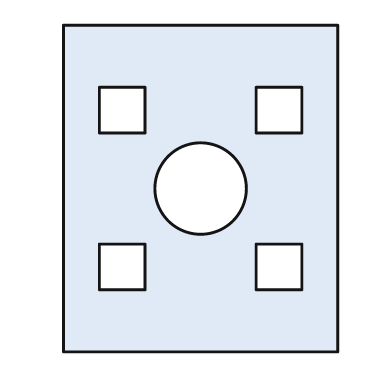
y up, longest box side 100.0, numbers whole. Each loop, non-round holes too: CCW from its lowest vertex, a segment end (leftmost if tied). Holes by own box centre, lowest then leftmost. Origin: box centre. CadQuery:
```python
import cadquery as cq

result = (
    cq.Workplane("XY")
    .moveTo(-42.0, -50.0)
    .lineTo(42.0, -50.0)
    .lineTo(42.0, 50.0)
    .lineTo(-42.0, 50.0)
    .close()
    .moveTo(-31.0, -31.0)
    .lineTo(-17.0, -31.0)
    .lineTo(-17.0, -17.0)
    .lineTo(-31.0, -17.0)
    .close()
    .moveTo(17.0, -31.0)
    .lineTo(31.0, -31.0)
    .lineTo(31.0, -17.0)
    .lineTo(17.0, -17.0)
    .close()
    .moveTo(0.0, 0.0)
    .circle(14.0)
    .moveTo(-31.0, 17.0)
    .lineTo(-17.0, 17.0)
    .lineTo(-17.0, 31.0)
    .lineTo(-31.0, 31.0)
    .close()
    .moveTo(17.0, 17.0)
    .lineTo(31.0, 17.0)
    .lineTo(31.0, 31.0)
    .lineTo(17.0, 31.0)
    .close()
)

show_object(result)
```